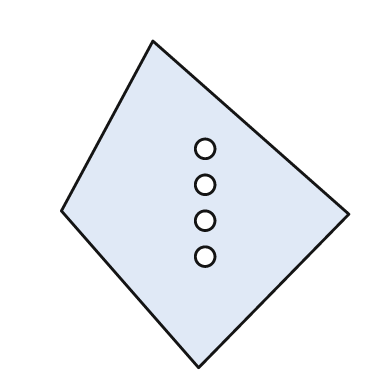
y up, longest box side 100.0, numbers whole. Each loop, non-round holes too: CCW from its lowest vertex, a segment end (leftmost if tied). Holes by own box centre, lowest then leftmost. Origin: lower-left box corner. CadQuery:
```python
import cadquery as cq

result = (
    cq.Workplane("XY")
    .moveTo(42.0, 0.0)
    .lineTo(88.0, 47.0)
    .lineTo(28.0, 100.0)
    .lineTo(0.0, 48.0)
    .close()
    .moveTo(44.0, 34.0)
    .circle(3.0)
    .moveTo(44.0, 45.0)
    .circle(3.0)
    .moveTo(44.0, 56.0)
    .circle(3.0)
    .moveTo(44.0, 67.0)
    .circle(3.0)
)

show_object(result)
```